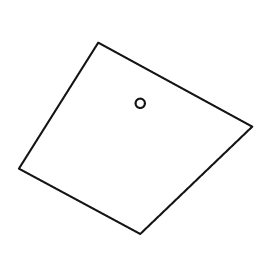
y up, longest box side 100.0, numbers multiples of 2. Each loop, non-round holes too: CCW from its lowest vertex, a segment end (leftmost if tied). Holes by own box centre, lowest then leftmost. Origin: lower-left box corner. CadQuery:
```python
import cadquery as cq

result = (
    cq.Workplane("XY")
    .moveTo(52.0, 0.0)
    .lineTo(100.0, 46.0)
    .lineTo(34.0, 82.0)
    .lineTo(0.0, 28.0)
    .close()
    .moveTo(52.0, 56.0)
    .circle(2.0)
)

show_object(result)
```